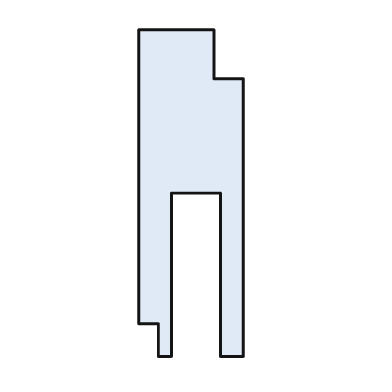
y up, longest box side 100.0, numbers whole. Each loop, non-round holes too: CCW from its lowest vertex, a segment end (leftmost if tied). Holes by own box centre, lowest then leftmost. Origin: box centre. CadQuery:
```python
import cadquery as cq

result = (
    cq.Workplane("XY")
    .moveTo(-10.0, -50.0)
    .lineTo(-6.0, -50.0)
    .lineTo(-6.0, 0.0)
    .lineTo(9.0, 0.0)
    .lineTo(9.0, -50.0)
    .lineTo(16.0, -50.0)
    .lineTo(16.0, 35.0)
    .lineTo(7.0, 35.0)
    .lineTo(7.0, 50.0)
    .lineTo(-16.0, 50.0)
    .lineTo(-16.0, -40.0)
    .lineTo(-10.0, -40.0)
    .close()
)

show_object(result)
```